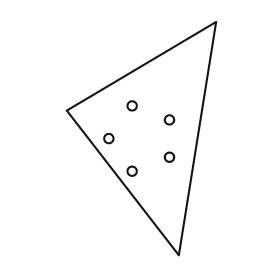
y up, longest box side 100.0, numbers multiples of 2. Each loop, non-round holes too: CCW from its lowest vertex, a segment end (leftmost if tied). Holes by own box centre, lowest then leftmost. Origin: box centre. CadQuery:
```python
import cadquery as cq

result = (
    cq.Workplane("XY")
    .moveTo(16.0, -50.0)
    .lineTo(32.0, 50.0)
    .lineTo(-32.0, 12.0)
    .close()
    .moveTo(-4.0, -14.0)
    .circle(2.0)
    .moveTo(12.0, -8.0)
    .circle(2.0)
    .moveTo(-14.0, 0.0)
    .circle(2.0)
    .moveTo(12.0, 8.0)
    .circle(2.0)
    .moveTo(-4.0, 14.0)
    .circle(2.0)
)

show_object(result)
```